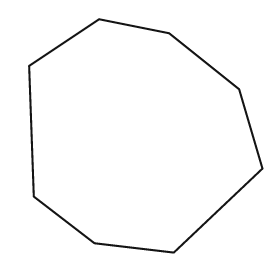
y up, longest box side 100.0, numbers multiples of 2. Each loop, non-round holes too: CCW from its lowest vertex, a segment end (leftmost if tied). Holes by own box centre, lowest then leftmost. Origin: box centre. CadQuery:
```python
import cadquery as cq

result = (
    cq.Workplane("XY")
    .moveTo(12.0, -50.0)
    .lineTo(50.0, -14.0)
    .lineTo(40.0, 20.0)
    .lineTo(10.0, 44.0)
    .lineTo(-20.0, 50.0)
    .lineTo(-50.0, 30.0)
    .lineTo(-48.0, -26.0)
    .lineTo(-22.0, -46.0)
    .close()
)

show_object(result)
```